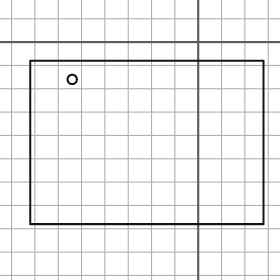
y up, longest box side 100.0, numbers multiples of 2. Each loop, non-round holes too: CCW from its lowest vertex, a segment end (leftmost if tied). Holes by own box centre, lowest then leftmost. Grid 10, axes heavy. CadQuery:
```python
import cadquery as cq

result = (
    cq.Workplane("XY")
    .moveTo(-72.0, -78.0)
    .lineTo(28.0, -78.0)
    .lineTo(28.0, -8.0)
    .lineTo(-72.0, -8.0)
    .close()
    .moveTo(-54.0, -16.0)
    .circle(2.0)
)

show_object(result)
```